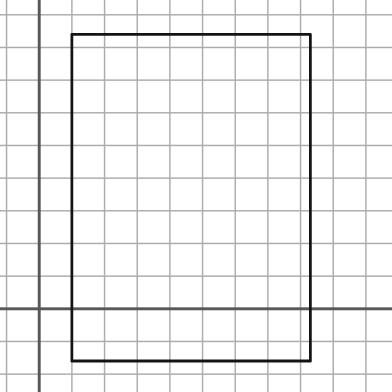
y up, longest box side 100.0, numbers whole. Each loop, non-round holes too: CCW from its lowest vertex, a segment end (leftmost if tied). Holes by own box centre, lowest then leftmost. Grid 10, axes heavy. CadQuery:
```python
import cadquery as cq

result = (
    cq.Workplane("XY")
    .moveTo(10.0, -16.0)
    .lineTo(83.0, -16.0)
    .lineTo(83.0, 84.0)
    .lineTo(10.0, 84.0)
    .close()
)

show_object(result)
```